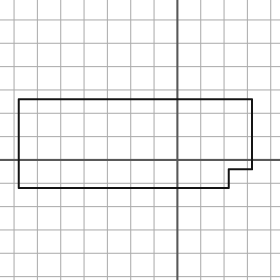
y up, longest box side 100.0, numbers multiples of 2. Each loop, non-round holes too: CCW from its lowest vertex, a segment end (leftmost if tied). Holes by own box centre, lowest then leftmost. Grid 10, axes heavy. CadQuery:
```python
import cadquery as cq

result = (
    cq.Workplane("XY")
    .moveTo(-68.0, -12.0)
    .lineTo(22.0, -12.0)
    .lineTo(22.0, -4.0)
    .lineTo(32.0, -4.0)
    .lineTo(32.0, 26.0)
    .lineTo(-68.0, 26.0)
    .close()
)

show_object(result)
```